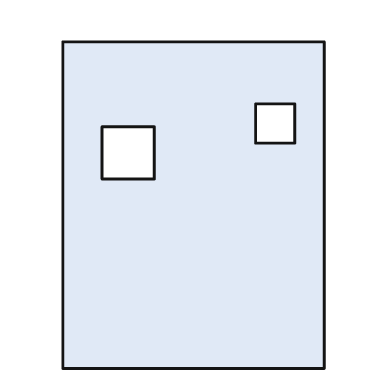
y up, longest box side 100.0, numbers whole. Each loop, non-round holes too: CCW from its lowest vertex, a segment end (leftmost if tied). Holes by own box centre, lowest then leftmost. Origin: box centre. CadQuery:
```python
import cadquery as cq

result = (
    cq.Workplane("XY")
    .moveTo(-40.0, -50.0)
    .lineTo(40.0, -50.0)
    .lineTo(40.0, 50.0)
    .lineTo(-40.0, 50.0)
    .close()
    .moveTo(-28.0, 8.0)
    .lineTo(-12.0, 8.0)
    .lineTo(-12.0, 24.0)
    .lineTo(-28.0, 24.0)
    .close()
    .moveTo(19.0, 19.0)
    .lineTo(31.0, 19.0)
    .lineTo(31.0, 31.0)
    .lineTo(19.0, 31.0)
    .close()
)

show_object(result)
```